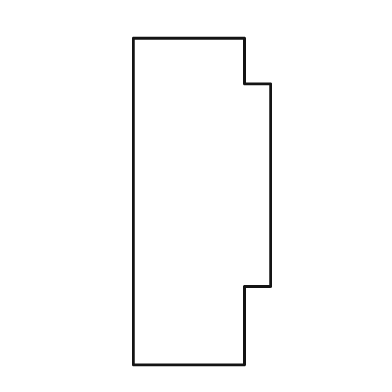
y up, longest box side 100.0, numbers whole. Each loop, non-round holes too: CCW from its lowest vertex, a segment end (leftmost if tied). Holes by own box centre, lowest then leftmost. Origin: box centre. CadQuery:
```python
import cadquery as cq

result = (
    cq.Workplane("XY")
    .moveTo(-21.0, -50.0)
    .lineTo(13.0, -50.0)
    .lineTo(13.0, -26.0)
    .lineTo(21.0, -26.0)
    .lineTo(21.0, 36.0)
    .lineTo(13.0, 36.0)
    .lineTo(13.0, 50.0)
    .lineTo(-21.0, 50.0)
    .close()
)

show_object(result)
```